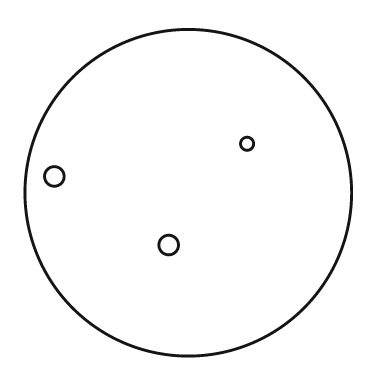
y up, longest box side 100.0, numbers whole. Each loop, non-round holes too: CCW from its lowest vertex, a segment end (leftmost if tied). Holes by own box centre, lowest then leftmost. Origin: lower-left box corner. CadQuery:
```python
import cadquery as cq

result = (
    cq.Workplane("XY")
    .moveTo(50.0, 50.0)
    .circle(50.0)
    .moveTo(44.0, 34.0)
    .circle(3.0)
    .moveTo(9.0, 55.0)
    .circle(3.0)
    .moveTo(68.0, 65.0)
    .circle(2.0)
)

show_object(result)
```